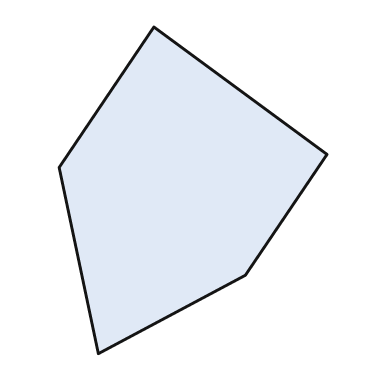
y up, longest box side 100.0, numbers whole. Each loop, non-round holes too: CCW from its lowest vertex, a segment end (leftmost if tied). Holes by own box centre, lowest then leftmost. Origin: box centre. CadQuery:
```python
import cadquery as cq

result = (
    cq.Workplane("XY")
    .moveTo(-29.0, -50.0)
    .lineTo(16.0, -26.0)
    .lineTo(41.0, 11.0)
    .lineTo(-12.0, 50.0)
    .lineTo(-41.0, 7.0)
    .close()
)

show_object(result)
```